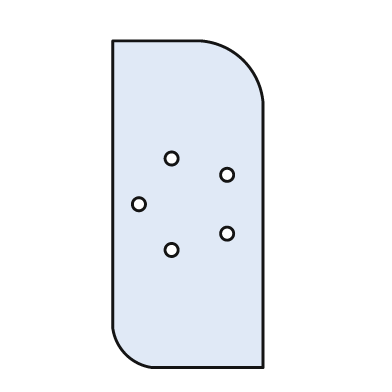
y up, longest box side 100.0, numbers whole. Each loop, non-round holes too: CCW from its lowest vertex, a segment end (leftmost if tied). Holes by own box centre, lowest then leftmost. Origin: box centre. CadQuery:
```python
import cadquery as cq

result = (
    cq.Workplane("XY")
    .moveTo(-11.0, -50.0)
    .lineTo(23.0, -50.0)
    .lineTo(23.0, 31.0)
    .threePointArc((17.0, 44.0), (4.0, 50.0))
    .lineTo(-23.0, 50.0)
    .lineTo(-23.0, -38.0)
    .threePointArc((-19.0, -46.0), (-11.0, -50.0))
    .close()
    .moveTo(-5.0, -14.0)
    .circle(2.0)
    .moveTo(12.0, -9.0)
    .circle(2.0)
    .moveTo(-15.0, 0.0)
    .circle(2.0)
    .moveTo(12.0, 9.0)
    .circle(2.0)
    .moveTo(-5.0, 14.0)
    .circle(2.0)
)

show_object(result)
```